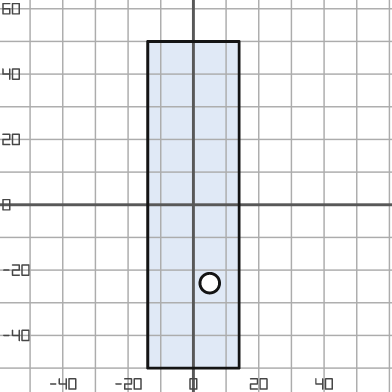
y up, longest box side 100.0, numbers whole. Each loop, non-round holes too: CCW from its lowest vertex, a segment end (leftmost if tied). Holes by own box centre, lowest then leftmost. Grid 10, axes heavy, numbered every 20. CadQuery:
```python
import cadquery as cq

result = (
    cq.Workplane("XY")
    .moveTo(-14.0, -50.0)
    .lineTo(14.0, -50.0)
    .lineTo(14.0, 50.0)
    .lineTo(-14.0, 50.0)
    .close()
    .moveTo(5.0, -24.0)
    .circle(3.0)
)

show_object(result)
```